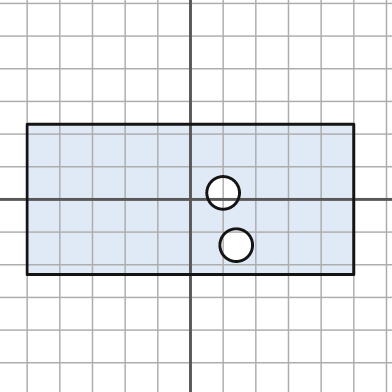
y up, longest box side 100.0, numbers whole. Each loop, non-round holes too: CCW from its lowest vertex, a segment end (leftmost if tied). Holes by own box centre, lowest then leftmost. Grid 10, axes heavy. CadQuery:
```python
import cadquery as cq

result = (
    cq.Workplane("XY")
    .moveTo(-50.0, -23.0)
    .lineTo(50.0, -23.0)
    .lineTo(50.0, 23.0)
    .lineTo(-50.0, 23.0)
    .close()
    .moveTo(14.0, -14.0)
    .circle(5.0)
    .moveTo(10.0, 2.0)
    .circle(5.0)
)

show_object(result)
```